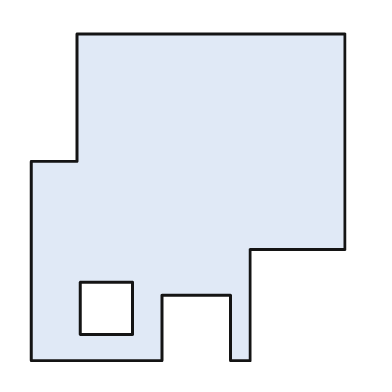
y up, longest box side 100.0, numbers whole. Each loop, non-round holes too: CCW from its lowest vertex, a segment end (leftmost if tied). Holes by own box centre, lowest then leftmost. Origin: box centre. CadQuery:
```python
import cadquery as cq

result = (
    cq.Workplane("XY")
    .moveTo(-48.0, -50.0)
    .lineTo(-8.0, -50.0)
    .lineTo(-8.0, -30.0)
    .lineTo(13.0, -30.0)
    .lineTo(13.0, -50.0)
    .lineTo(19.0, -50.0)
    .lineTo(19.0, -16.0)
    .lineTo(48.0, -16.0)
    .lineTo(48.0, 50.0)
    .lineTo(-34.0, 50.0)
    .lineTo(-34.0, 11.0)
    .lineTo(-48.0, 11.0)
    .close()
    .moveTo(-33.0, -42.0)
    .lineTo(-17.0, -42.0)
    .lineTo(-17.0, -26.0)
    .lineTo(-33.0, -26.0)
    .close()
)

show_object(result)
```